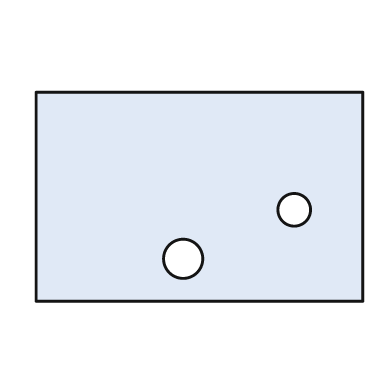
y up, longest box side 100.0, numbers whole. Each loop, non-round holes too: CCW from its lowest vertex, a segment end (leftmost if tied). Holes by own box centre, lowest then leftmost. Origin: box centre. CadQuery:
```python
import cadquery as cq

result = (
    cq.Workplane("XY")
    .moveTo(-50.0, -32.0)
    .lineTo(50.0, -32.0)
    .lineTo(50.0, 32.0)
    .lineTo(-50.0, 32.0)
    .close()
    .moveTo(-5.0, -19.0)
    .circle(6.0)
    .moveTo(29.0, -4.0)
    .circle(5.0)
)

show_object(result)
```